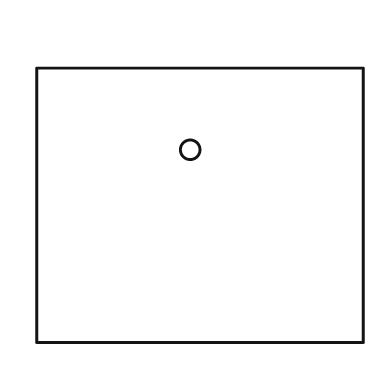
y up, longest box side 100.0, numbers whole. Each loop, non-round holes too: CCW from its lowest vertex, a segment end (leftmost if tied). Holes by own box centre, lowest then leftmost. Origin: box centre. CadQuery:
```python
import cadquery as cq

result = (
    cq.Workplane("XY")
    .moveTo(-50.0, -42.0)
    .lineTo(50.0, -42.0)
    .lineTo(50.0, 42.0)
    .lineTo(-50.0, 42.0)
    .close()
    .moveTo(-3.0, 17.0)
    .circle(3.0)
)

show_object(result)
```